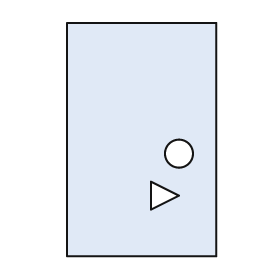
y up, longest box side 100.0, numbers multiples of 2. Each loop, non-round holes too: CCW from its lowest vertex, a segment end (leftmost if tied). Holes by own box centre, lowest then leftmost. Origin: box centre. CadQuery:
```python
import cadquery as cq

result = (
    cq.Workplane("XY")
    .moveTo(-32.0, -50.0)
    .lineTo(32.0, -50.0)
    .lineTo(32.0, 50.0)
    .lineTo(-32.0, 50.0)
    .close()
    .moveTo(4.0, -30.0)
    .lineTo(16.0, -24.0)
    .lineTo(4.0, -18.0)
    .close()
    .moveTo(16.0, -6.0)
    .circle(6.0)
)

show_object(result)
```